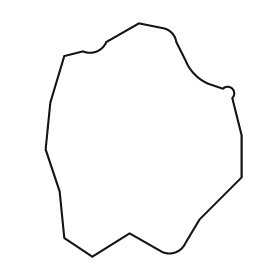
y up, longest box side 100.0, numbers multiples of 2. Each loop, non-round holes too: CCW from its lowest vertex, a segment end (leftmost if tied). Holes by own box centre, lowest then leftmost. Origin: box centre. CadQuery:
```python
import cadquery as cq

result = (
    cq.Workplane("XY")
    .moveTo(-22.0, -50.0)
    .lineTo(-6.0, -40.0)
    .lineTo(8.0, -48.0)
    .threePointArc((14.0, -48.0), (18.0, -44.0))
    .lineTo(24.0, -34.0)
    .lineTo(42.0, -16.0)
    .lineTo(42.0, 2.0)
    .lineTo(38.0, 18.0)
    .threePointArc((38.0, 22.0), (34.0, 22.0))
    .lineTo(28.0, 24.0)
    .threePointArc((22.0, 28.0), (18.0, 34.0))
    .lineTo(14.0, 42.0)
    .threePointArc((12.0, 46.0), (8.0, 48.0))
    .lineTo(-2.0, 50.0)
    .lineTo(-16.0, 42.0)
    .threePointArc((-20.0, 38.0), (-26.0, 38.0))
    .lineTo(-34.0, 36.0)
    .lineTo(-40.0, 16.0)
    .lineTo(-42.0, -4.0)
    .lineTo(-36.0, -22.0)
    .lineTo(-34.0, -42.0)
    .close()
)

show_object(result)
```